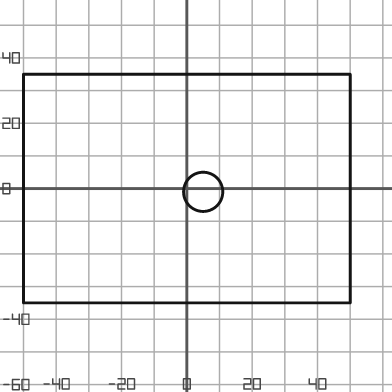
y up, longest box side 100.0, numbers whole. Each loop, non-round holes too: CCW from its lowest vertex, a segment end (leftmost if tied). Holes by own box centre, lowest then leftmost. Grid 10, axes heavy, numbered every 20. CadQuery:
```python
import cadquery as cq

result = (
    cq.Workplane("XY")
    .moveTo(-50.0, -35.0)
    .lineTo(50.0, -35.0)
    .lineTo(50.0, 35.0)
    .lineTo(-50.0, 35.0)
    .close()
    .moveTo(5.0, -1.0)
    .circle(6.0)
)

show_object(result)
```